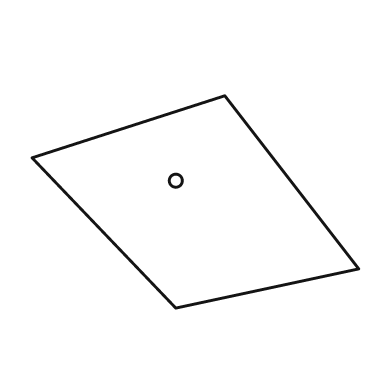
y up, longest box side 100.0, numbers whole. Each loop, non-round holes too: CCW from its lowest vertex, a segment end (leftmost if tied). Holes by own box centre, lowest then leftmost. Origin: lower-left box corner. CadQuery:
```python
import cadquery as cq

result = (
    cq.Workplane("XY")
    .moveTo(44.0, 0.0)
    .lineTo(100.0, 12.0)
    .lineTo(59.0, 65.0)
    .lineTo(0.0, 46.0)
    .close()
    .moveTo(44.0, 39.0)
    .circle(2.0)
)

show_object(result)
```